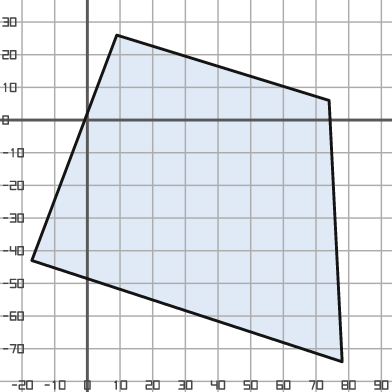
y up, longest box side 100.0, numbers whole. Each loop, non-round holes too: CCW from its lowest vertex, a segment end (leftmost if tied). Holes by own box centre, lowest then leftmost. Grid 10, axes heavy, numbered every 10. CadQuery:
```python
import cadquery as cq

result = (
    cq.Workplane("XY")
    .moveTo(78.0, -74.0)
    .lineTo(74.0, 6.0)
    .lineTo(9.0, 26.0)
    .lineTo(-17.0, -43.0)
    .close()
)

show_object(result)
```